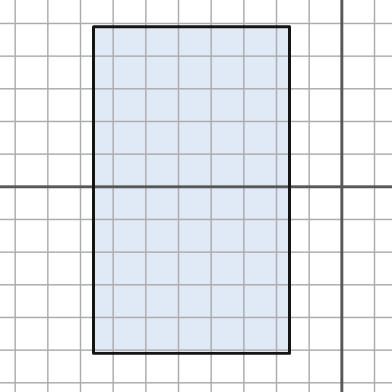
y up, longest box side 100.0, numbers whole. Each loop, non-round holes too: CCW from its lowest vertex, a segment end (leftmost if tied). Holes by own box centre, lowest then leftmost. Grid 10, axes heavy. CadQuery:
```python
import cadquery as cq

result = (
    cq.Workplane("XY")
    .moveTo(-76.0, -51.0)
    .lineTo(-16.0, -51.0)
    .lineTo(-16.0, 49.0)
    .lineTo(-76.0, 49.0)
    .close()
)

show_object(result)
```